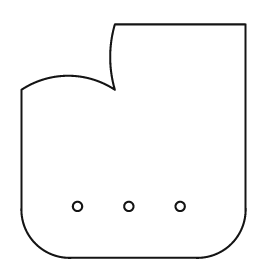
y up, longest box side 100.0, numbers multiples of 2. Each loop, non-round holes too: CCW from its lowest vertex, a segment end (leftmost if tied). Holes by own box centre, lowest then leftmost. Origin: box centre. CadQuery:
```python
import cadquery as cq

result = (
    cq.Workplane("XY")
    .moveTo(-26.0, -50.0)
    .lineTo(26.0, -50.0)
    .threePointArc((42.0, -44.0), (48.0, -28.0))
    .lineTo(48.0, 50.0)
    .lineTo(-8.0, 50.0)
    .threePointArc((-10.0, 36.0), (-8.0, 22.0))
    .threePointArc((-28.0, 28.0), (-48.0, 22.0))
    .lineTo(-48.0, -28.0)
    .threePointArc((-42.0, -44.0), (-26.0, -50.0))
    .close()
    .moveTo(-24.0, -28.0)
    .circle(2.0)
    .moveTo(-2.0, -28.0)
    .circle(2.0)
    .moveTo(20.0, -28.0)
    .circle(2.0)
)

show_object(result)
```